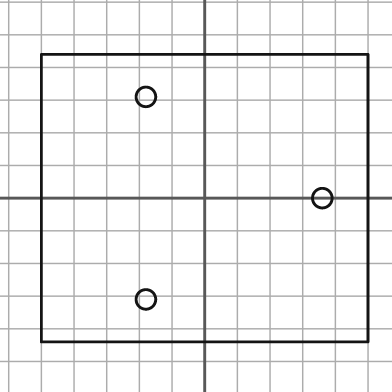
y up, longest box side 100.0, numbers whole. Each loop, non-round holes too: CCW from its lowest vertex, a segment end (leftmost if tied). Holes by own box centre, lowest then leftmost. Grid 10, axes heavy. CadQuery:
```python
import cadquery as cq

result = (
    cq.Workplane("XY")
    .moveTo(-50.0, -44.0)
    .lineTo(50.0, -44.0)
    .lineTo(50.0, 44.0)
    .lineTo(-50.0, 44.0)
    .close()
    .moveTo(-18.0, -31.0)
    .circle(3.0)
    .moveTo(36.0, 0.0)
    .circle(3.0)
    .moveTo(-18.0, 31.0)
    .circle(3.0)
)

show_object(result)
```